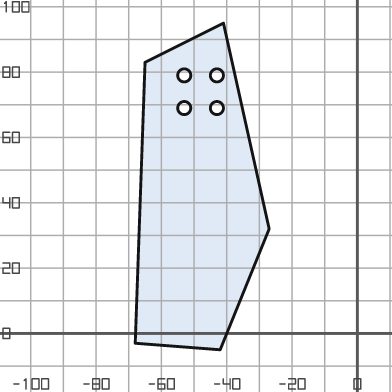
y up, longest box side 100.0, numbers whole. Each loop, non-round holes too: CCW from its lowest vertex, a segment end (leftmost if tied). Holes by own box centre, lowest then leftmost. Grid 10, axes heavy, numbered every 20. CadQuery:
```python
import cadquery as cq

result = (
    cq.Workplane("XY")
    .moveTo(-42.0, -5.0)
    .lineTo(-27.0, 32.0)
    .lineTo(-41.0, 95.0)
    .lineTo(-65.0, 83.0)
    .lineTo(-68.0, -3.0)
    .close()
    .moveTo(-53.0, 69.0)
    .circle(2.0)
    .moveTo(-43.0, 69.0)
    .circle(2.0)
    .moveTo(-53.0, 79.0)
    .circle(2.0)
    .moveTo(-43.0, 79.0)
    .circle(2.0)
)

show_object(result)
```